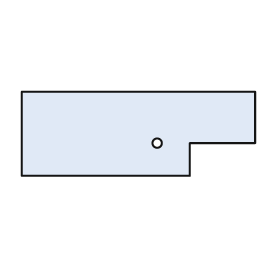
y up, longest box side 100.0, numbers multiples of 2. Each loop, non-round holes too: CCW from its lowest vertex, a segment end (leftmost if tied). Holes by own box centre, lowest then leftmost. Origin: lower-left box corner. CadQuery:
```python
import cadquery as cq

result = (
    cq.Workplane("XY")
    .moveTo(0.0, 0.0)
    .lineTo(72.0, 0.0)
    .lineTo(72.0, 14.0)
    .lineTo(100.0, 14.0)
    .lineTo(100.0, 36.0)
    .lineTo(0.0, 36.0)
    .close()
    .moveTo(58.0, 14.0)
    .circle(2.0)
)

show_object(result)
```